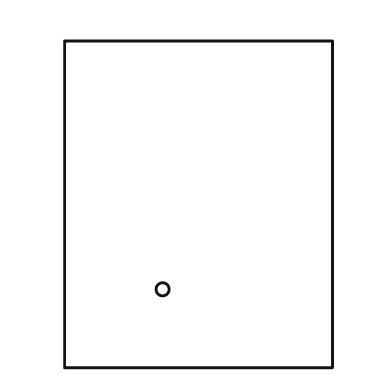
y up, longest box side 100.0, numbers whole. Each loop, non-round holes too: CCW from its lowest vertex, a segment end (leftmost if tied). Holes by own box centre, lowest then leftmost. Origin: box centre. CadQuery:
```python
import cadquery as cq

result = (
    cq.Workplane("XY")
    .moveTo(-41.0, -50.0)
    .lineTo(41.0, -50.0)
    .lineTo(41.0, 50.0)
    .lineTo(-41.0, 50.0)
    .close()
    .moveTo(-11.0, -26.0)
    .circle(2.0)
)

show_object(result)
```